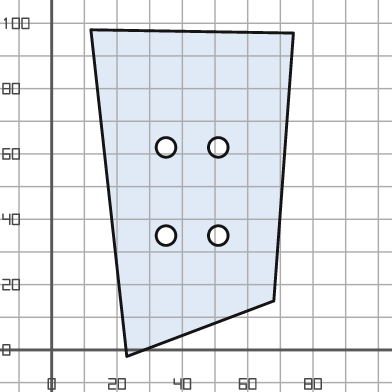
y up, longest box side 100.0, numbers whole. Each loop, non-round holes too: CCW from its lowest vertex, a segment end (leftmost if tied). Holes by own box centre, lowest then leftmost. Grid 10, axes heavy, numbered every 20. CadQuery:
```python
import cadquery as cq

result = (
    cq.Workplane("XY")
    .moveTo(23.0, -2.0)
    .lineTo(68.0, 15.0)
    .lineTo(74.0, 97.0)
    .lineTo(12.0, 98.0)
    .close()
    .moveTo(35.0, 35.0)
    .circle(3.0)
    .moveTo(51.0, 35.0)
    .circle(3.0)
    .moveTo(35.0, 62.0)
    .circle(3.0)
    .moveTo(51.0, 62.0)
    .circle(3.0)
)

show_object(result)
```